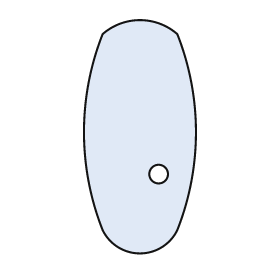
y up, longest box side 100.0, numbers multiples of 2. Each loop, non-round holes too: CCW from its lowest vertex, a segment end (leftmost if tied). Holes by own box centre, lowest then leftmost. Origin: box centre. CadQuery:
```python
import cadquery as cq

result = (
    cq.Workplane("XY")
    .moveTo(-16.0, -40.0)
    .threePointArc((0.0, -50.0), (16.0, -40.0))
    .threePointArc((24.0, 2.0), (16.0, 44.0))
    .threePointArc((0.0, 50.0), (-16.0, 44.0))
    .threePointArc((-24.0, 2.0), (-16.0, -40.0))
    .close()
    .moveTo(8.0, -16.0)
    .circle(4.0)
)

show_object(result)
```